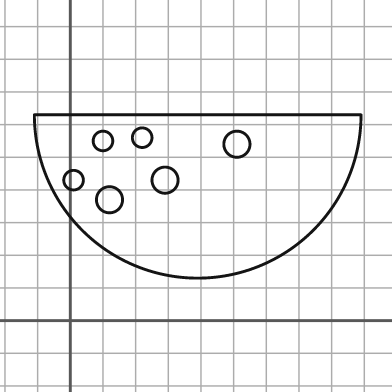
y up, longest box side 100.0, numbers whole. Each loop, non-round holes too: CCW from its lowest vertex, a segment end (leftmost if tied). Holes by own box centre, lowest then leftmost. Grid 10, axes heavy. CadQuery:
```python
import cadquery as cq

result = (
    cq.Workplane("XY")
    .moveTo(-11.0, 63.0)
    .threePointArc((39.0, 13.0), (89.0, 63.0))
    .close()
    .moveTo(12.0, 37.0)
    .circle(4.0)
    .moveTo(1.0, 43.0)
    .circle(3.0)
    .moveTo(29.0, 43.0)
    .circle(4.0)
    .moveTo(51.0, 54.0)
    .circle(4.0)
    .moveTo(10.0, 55.0)
    .circle(3.0)
    .moveTo(22.0, 56.0)
    .circle(3.0)
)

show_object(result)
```